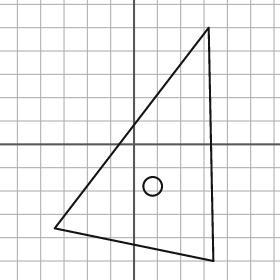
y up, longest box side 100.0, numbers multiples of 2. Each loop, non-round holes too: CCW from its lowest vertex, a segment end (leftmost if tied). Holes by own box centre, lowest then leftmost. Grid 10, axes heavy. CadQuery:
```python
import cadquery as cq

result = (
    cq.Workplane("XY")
    .moveTo(34.0, -50.0)
    .lineTo(32.0, 50.0)
    .lineTo(-34.0, -36.0)
    .close()
    .moveTo(8.0, -18.0)
    .circle(4.0)
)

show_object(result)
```